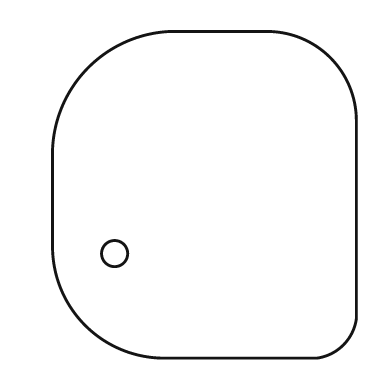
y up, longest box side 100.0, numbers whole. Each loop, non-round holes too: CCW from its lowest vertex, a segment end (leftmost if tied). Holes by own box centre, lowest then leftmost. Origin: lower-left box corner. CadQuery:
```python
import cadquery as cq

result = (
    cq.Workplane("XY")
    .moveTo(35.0, 0.0)
    .lineTo(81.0, 0.0)
    .threePointArc((89.0, 4.0), (93.0, 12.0))
    .lineTo(93.0, 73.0)
    .threePointArc((85.0, 92.0), (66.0, 100.0))
    .lineTo(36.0, 100.0)
    .threePointArc((11.0, 89.0), (0.0, 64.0))
    .lineTo(0.0, 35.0)
    .threePointArc((10.0, 10.0), (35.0, 0.0))
    .close()
    .moveTo(19.0, 32.0)
    .circle(4.0)
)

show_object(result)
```